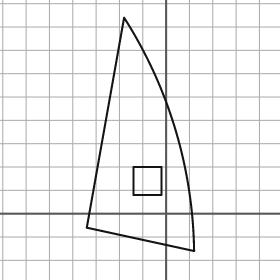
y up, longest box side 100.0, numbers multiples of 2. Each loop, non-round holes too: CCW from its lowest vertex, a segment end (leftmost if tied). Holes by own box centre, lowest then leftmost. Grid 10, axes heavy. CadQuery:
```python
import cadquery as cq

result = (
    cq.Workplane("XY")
    .moveTo(12.0, -16.0)
    .threePointArc((4.0, 36.0), (-18.0, 84.0))
    .lineTo(-34.0, -6.0)
    .close()
    .moveTo(-14.0, 8.0)
    .lineTo(-2.0, 8.0)
    .lineTo(-2.0, 20.0)
    .lineTo(-14.0, 20.0)
    .close()
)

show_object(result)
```